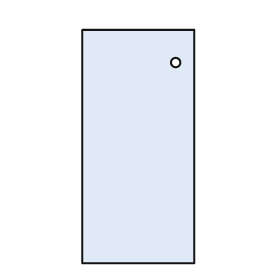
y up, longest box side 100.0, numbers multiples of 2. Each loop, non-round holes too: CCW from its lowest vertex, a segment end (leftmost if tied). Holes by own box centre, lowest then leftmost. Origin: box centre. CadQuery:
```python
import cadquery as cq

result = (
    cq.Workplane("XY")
    .moveTo(-24.0, -50.0)
    .lineTo(24.0, -50.0)
    .lineTo(24.0, 50.0)
    .lineTo(-24.0, 50.0)
    .close()
    .moveTo(16.0, 36.0)
    .circle(2.0)
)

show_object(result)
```